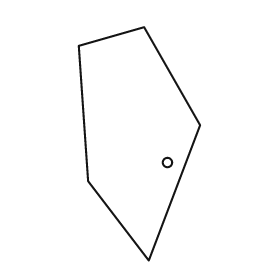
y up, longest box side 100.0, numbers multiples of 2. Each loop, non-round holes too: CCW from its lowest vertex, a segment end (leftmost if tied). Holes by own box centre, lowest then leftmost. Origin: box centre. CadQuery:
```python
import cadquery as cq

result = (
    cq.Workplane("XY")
    .moveTo(4.0, -50.0)
    .lineTo(26.0, 8.0)
    .lineTo(2.0, 50.0)
    .lineTo(-26.0, 42.0)
    .lineTo(-22.0, -16.0)
    .close()
    .moveTo(12.0, -8.0)
    .circle(2.0)
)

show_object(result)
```